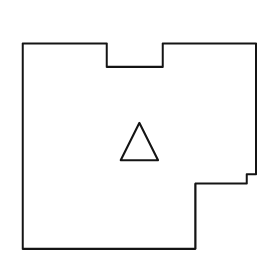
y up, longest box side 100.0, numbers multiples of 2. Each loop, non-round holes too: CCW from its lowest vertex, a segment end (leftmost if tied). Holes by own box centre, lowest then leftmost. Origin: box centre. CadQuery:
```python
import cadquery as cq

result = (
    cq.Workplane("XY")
    .moveTo(-50.0, -44.0)
    .lineTo(24.0, -44.0)
    .lineTo(24.0, -16.0)
    .lineTo(46.0, -16.0)
    .lineTo(46.0, -12.0)
    .lineTo(50.0, -12.0)
    .lineTo(50.0, 44.0)
    .lineTo(10.0, 44.0)
    .lineTo(10.0, 34.0)
    .lineTo(-14.0, 34.0)
    .lineTo(-14.0, 44.0)
    .lineTo(-50.0, 44.0)
    .close()
    .moveTo(-8.0, -6.0)
    .lineTo(8.0, -6.0)
    .lineTo(0.0, 10.0)
    .close()
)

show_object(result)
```